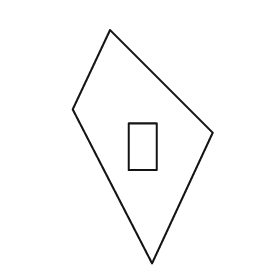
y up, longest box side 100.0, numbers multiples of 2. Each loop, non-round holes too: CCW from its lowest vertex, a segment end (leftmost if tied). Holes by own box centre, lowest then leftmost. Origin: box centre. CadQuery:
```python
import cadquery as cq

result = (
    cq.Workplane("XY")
    .moveTo(4.0, -50.0)
    .lineTo(30.0, 6.0)
    .lineTo(-14.0, 50.0)
    .lineTo(-30.0, 16.0)
    .close()
    .moveTo(-6.0, -10.0)
    .lineTo(6.0, -10.0)
    .lineTo(6.0, 10.0)
    .lineTo(-6.0, 10.0)
    .close()
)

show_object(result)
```